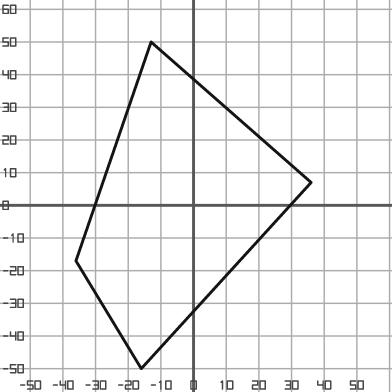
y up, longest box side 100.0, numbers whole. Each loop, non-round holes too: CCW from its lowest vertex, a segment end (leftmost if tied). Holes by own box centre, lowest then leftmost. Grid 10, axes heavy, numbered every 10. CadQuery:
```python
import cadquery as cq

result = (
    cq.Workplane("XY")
    .moveTo(-16.0, -50.0)
    .lineTo(36.0, 7.0)
    .lineTo(-13.0, 50.0)
    .lineTo(-36.0, -17.0)
    .close()
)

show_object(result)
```